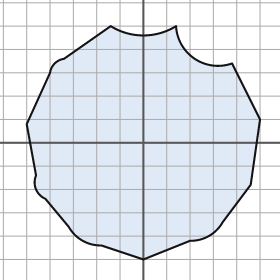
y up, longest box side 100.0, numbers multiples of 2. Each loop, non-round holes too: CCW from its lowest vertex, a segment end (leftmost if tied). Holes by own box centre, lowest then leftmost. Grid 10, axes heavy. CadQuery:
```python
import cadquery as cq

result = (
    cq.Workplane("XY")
    .moveTo(0.0, -50.0)
    .lineTo(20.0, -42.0)
    .threePointArc((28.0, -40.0), (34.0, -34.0))
    .lineTo(46.0, -18.0)
    .lineTo(50.0, 10.0)
    .lineTo(38.0, 34.0)
    .threePointArc((22.0, 36.0), (14.0, 50.0))
    .threePointArc((0.0, 46.0), (-14.0, 50.0))
    .lineTo(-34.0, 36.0)
    .threePointArc((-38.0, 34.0), (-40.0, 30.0))
    .lineTo(-50.0, 8.0)
    .lineTo(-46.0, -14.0)
    .threePointArc((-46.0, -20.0), (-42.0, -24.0))
    .lineTo(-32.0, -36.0)
    .threePointArc((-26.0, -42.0), (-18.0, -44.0))
    .close()
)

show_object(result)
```